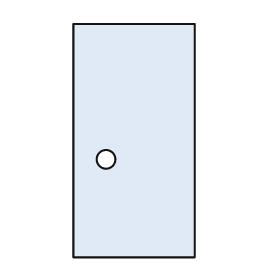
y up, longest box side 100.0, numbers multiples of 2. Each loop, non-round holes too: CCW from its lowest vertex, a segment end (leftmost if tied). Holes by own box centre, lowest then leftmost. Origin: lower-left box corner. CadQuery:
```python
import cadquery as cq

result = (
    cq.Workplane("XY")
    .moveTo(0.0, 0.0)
    .lineTo(52.0, 0.0)
    .lineTo(52.0, 100.0)
    .lineTo(0.0, 100.0)
    .close()
    .moveTo(14.0, 42.0)
    .circle(4.0)
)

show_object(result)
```